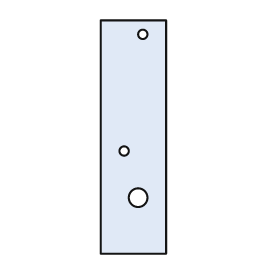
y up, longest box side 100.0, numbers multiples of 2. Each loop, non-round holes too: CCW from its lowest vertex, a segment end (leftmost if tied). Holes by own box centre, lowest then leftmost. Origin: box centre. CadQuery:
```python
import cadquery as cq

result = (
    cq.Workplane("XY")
    .moveTo(-14.0, -50.0)
    .lineTo(14.0, -50.0)
    .lineTo(14.0, 50.0)
    .lineTo(-14.0, 50.0)
    .close()
    .moveTo(2.0, -26.0)
    .circle(4.0)
    .moveTo(-4.0, -6.0)
    .circle(2.0)
    .moveTo(4.0, 44.0)
    .circle(2.0)
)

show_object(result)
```